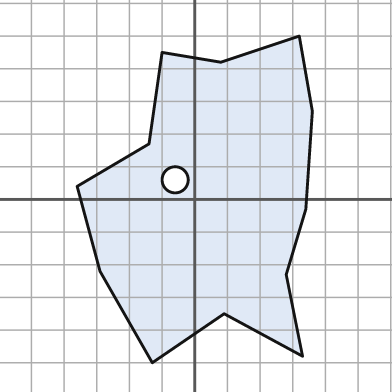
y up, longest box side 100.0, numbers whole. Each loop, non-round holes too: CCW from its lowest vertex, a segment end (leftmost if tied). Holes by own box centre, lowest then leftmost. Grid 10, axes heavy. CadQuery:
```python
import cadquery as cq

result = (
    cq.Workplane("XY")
    .moveTo(-13.0, -50.0)
    .lineTo(9.0, -35.0)
    .lineTo(33.0, -48.0)
    .lineTo(28.0, -23.0)
    .lineTo(34.0, -3.0)
    .lineTo(36.0, 27.0)
    .lineTo(32.0, 50.0)
    .lineTo(8.0, 42.0)
    .lineTo(-10.0, 45.0)
    .lineTo(-14.0, 17.0)
    .lineTo(-36.0, 4.0)
    .lineTo(-29.0, -22.0)
    .close()
    .moveTo(-6.0, 6.0)
    .circle(4.0)
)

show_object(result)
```